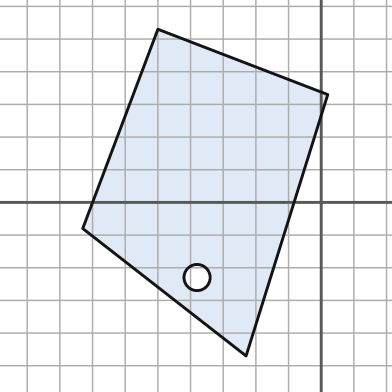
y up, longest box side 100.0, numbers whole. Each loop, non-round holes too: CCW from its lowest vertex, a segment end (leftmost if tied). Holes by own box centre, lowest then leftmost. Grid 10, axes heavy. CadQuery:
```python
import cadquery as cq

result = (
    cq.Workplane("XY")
    .moveTo(-23.0, -47.0)
    .lineTo(2.0, 33.0)
    .lineTo(-50.0, 53.0)
    .lineTo(-73.0, -8.0)
    .close()
    .moveTo(-38.0, -23.0)
    .circle(4.0)
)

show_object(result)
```